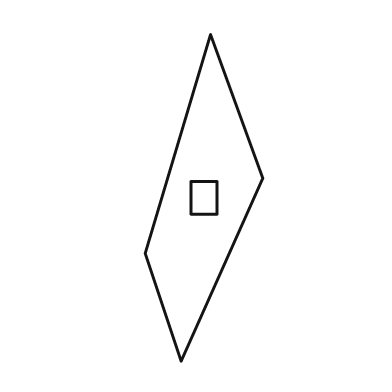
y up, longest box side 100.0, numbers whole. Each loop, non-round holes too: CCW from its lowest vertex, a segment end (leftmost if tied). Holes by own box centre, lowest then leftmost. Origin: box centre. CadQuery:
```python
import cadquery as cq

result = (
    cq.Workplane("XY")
    .moveTo(-7.0, -50.0)
    .lineTo(18.0, 6.0)
    .lineTo(2.0, 50.0)
    .lineTo(-18.0, -17.0)
    .close()
    .moveTo(-4.0, -5.0)
    .lineTo(4.0, -5.0)
    .lineTo(4.0, 5.0)
    .lineTo(-4.0, 5.0)
    .close()
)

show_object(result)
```